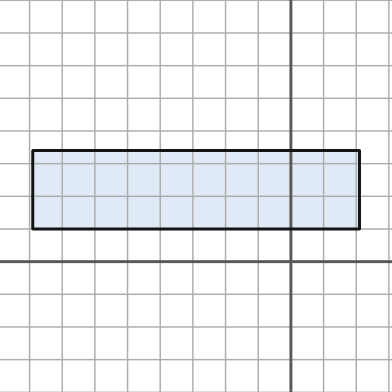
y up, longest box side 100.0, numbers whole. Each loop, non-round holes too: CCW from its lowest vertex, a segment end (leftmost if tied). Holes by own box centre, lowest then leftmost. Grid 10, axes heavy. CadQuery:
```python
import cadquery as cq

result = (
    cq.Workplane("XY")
    .moveTo(-79.0, 10.0)
    .lineTo(21.0, 10.0)
    .lineTo(21.0, 34.0)
    .lineTo(-79.0, 34.0)
    .close()
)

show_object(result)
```